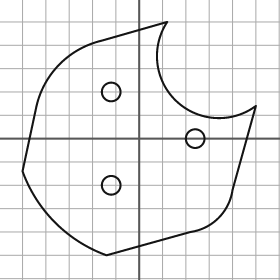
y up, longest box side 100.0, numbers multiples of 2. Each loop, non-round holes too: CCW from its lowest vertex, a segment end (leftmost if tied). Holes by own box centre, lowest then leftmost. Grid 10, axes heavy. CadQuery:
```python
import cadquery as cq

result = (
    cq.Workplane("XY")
    .moveTo(-14.0, -50.0)
    .lineTo(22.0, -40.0)
    .threePointArc((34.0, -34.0), (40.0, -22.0))
    .lineTo(50.0, 14.0)
    .threePointArc((16.0, 16.0), (12.0, 50.0))
    .lineTo(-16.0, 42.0)
    .threePointArc((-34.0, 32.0), (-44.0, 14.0))
    .lineTo(-50.0, -14.0)
    .threePointArc((-36.0, -36.0), (-14.0, -50.0))
    .close()
    .moveTo(-12.0, -20.0)
    .circle(4.0)
    .moveTo(24.0, 0.0)
    .circle(4.0)
    .moveTo(-12.0, 20.0)
    .circle(4.0)
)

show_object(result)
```